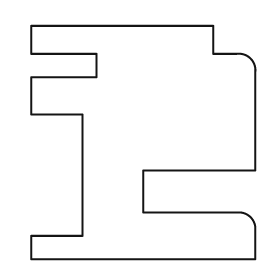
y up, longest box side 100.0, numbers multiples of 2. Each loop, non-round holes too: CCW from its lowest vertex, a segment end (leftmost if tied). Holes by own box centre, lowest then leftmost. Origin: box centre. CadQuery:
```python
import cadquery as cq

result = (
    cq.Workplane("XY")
    .moveTo(-48.0, -50.0)
    .lineTo(48.0, -50.0)
    .lineTo(48.0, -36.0)
    .threePointArc((46.0, -32.0), (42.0, -30.0))
    .lineTo(0.0, -30.0)
    .lineTo(0.0, -12.0)
    .lineTo(48.0, -12.0)
    .lineTo(48.0, 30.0)
    .threePointArc((46.0, 36.0), (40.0, 38.0))
    .lineTo(30.0, 38.0)
    .lineTo(30.0, 50.0)
    .lineTo(-48.0, 50.0)
    .lineTo(-48.0, 38.0)
    .lineTo(-20.0, 38.0)
    .lineTo(-20.0, 28.0)
    .lineTo(-48.0, 28.0)
    .lineTo(-48.0, 12.0)
    .lineTo(-26.0, 12.0)
    .lineTo(-26.0, -40.0)
    .lineTo(-48.0, -40.0)
    .close()
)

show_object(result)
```